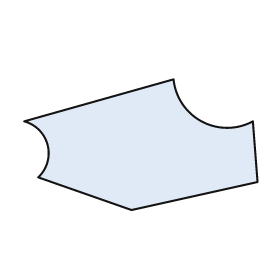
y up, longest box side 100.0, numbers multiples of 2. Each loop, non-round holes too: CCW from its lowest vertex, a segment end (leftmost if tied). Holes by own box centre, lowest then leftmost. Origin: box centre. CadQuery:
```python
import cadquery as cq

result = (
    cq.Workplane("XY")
    .moveTo(-4.0, -28.0)
    .lineTo(50.0, -16.0)
    .lineTo(48.0, 10.0)
    .threePointArc((26.0, 10.0), (14.0, 28.0))
    .lineTo(-50.0, 10.0)
    .threePointArc((-40.0, 0.0), (-44.0, -14.0))
    .close()
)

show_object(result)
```